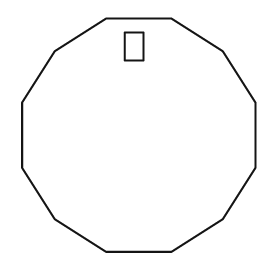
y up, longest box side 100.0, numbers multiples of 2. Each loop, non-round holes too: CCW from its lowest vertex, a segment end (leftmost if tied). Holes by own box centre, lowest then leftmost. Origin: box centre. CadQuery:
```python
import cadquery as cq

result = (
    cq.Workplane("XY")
    .moveTo(-14.0, -50.0)
    .lineTo(14.0, -50.0)
    .lineTo(36.0, -36.0)
    .lineTo(50.0, -14.0)
    .lineTo(50.0, 14.0)
    .lineTo(36.0, 36.0)
    .lineTo(14.0, 50.0)
    .lineTo(-14.0, 50.0)
    .lineTo(-36.0, 36.0)
    .lineTo(-50.0, 14.0)
    .lineTo(-50.0, -14.0)
    .lineTo(-36.0, -36.0)
    .close()
    .moveTo(-6.0, 32.0)
    .lineTo(2.0, 32.0)
    .lineTo(2.0, 44.0)
    .lineTo(-6.0, 44.0)
    .close()
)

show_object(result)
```